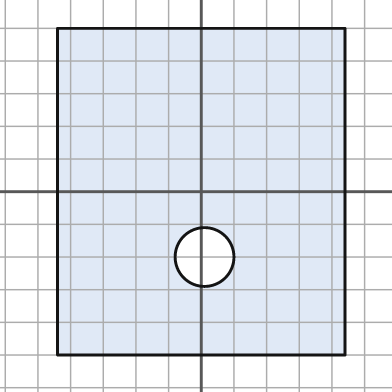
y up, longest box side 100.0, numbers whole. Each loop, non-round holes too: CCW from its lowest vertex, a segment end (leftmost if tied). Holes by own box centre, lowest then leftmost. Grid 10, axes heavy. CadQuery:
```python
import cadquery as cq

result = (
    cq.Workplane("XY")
    .moveTo(-44.0, -50.0)
    .lineTo(44.0, -50.0)
    .lineTo(44.0, 50.0)
    .lineTo(-44.0, 50.0)
    .close()
    .moveTo(1.0, -20.0)
    .circle(9.0)
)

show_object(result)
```